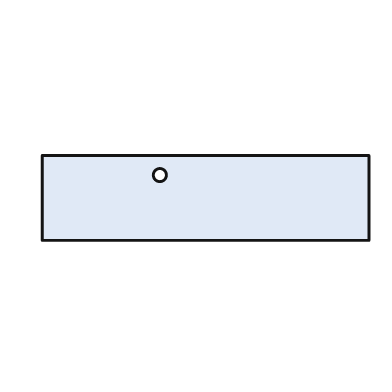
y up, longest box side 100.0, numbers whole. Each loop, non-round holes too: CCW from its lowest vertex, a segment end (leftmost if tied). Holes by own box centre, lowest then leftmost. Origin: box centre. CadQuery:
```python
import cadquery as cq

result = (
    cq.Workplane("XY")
    .moveTo(-50.0, -13.0)
    .lineTo(50.0, -13.0)
    .lineTo(50.0, 13.0)
    .lineTo(-50.0, 13.0)
    .close()
    .moveTo(-14.0, 7.0)
    .circle(2.0)
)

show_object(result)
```